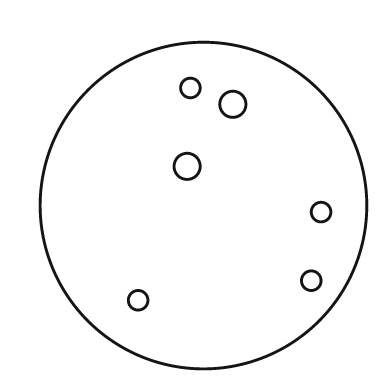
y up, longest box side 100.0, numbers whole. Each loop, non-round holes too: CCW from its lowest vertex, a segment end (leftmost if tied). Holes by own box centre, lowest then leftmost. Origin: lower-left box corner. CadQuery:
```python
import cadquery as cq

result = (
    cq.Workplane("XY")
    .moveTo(50.0, 50.0)
    .circle(50.0)
    .moveTo(30.0, 21.0)
    .circle(3.0)
    .moveTo(83.0, 27.0)
    .circle(3.0)
    .moveTo(86.0, 48.0)
    .circle(3.0)
    .moveTo(45.0, 62.0)
    .circle(4.0)
    .moveTo(59.0, 81.0)
    .circle(4.0)
    .moveTo(46.0, 86.0)
    .circle(3.0)
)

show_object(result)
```